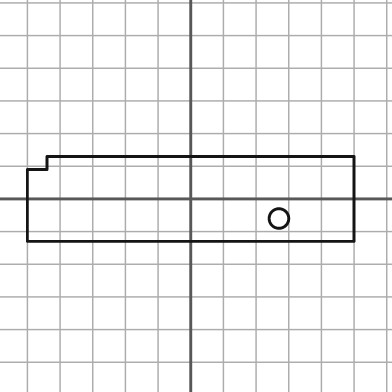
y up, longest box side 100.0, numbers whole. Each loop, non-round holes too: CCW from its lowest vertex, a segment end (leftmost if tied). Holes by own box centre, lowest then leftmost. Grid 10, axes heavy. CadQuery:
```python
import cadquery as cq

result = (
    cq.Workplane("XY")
    .moveTo(-50.0, -13.0)
    .lineTo(50.0, -13.0)
    .lineTo(50.0, 13.0)
    .lineTo(-44.0, 13.0)
    .lineTo(-44.0, 9.0)
    .lineTo(-50.0, 9.0)
    .close()
    .moveTo(27.0, -6.0)
    .circle(3.0)
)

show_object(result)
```